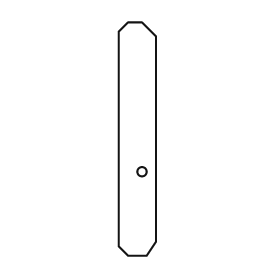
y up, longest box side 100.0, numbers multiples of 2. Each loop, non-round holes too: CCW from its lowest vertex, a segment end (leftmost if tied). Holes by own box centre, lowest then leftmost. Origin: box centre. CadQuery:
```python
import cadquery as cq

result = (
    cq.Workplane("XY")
    .moveTo(-4.0, -50.0)
    .lineTo(4.0, -50.0)
    .lineTo(8.0, -44.0)
    .lineTo(8.0, 44.0)
    .lineTo(2.0, 50.0)
    .lineTo(-4.0, 50.0)
    .lineTo(-8.0, 46.0)
    .lineTo(-8.0, -46.0)
    .close()
    .moveTo(2.0, -14.0)
    .circle(2.0)
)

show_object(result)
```